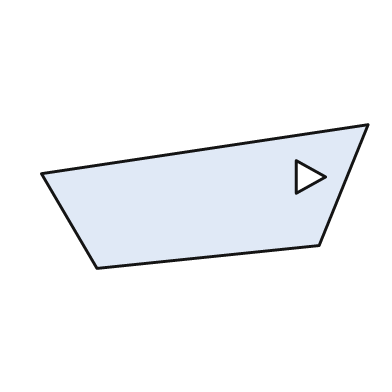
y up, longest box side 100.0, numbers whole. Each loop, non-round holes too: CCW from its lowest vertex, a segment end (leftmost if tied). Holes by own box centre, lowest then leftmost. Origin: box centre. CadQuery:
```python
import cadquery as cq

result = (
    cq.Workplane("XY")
    .moveTo(-33.0, -22.0)
    .lineTo(35.0, -15.0)
    .lineTo(50.0, 22.0)
    .lineTo(-50.0, 7.0)
    .close()
    .moveTo(28.0, 1.0)
    .lineTo(37.0, 6.0)
    .lineTo(28.0, 11.0)
    .close()
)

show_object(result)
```